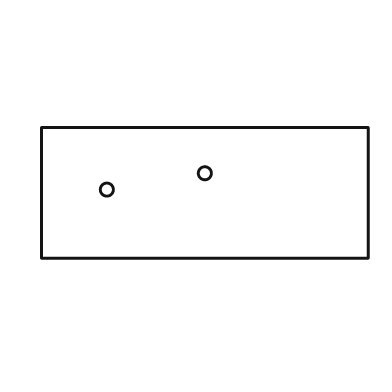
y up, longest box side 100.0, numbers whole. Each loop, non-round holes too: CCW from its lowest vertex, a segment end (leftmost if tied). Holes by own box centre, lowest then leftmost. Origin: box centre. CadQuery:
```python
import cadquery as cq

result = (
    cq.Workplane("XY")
    .moveTo(-50.0, -20.0)
    .lineTo(50.0, -20.0)
    .lineTo(50.0, 20.0)
    .lineTo(-50.0, 20.0)
    .close()
    .moveTo(-30.0, 1.0)
    .circle(2.0)
    .moveTo(0.0, 6.0)
    .circle(2.0)
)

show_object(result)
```